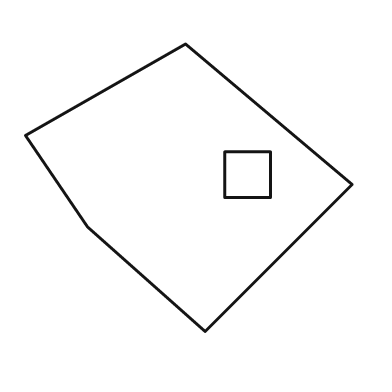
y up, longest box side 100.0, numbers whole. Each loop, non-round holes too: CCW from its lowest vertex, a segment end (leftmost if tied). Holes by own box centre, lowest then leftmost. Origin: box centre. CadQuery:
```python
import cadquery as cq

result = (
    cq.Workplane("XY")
    .moveTo(5.0, -44.0)
    .lineTo(50.0, 1.0)
    .lineTo(-1.0, 44.0)
    .lineTo(-50.0, 16.0)
    .lineTo(-31.0, -12.0)
    .close()
    .moveTo(11.0, -3.0)
    .lineTo(25.0, -3.0)
    .lineTo(25.0, 11.0)
    .lineTo(11.0, 11.0)
    .close()
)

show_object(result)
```